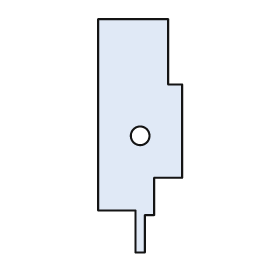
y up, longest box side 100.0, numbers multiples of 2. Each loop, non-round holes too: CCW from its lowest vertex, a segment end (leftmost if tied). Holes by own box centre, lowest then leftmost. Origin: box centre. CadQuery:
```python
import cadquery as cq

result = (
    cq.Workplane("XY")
    .moveTo(-2.0, -50.0)
    .lineTo(2.0, -50.0)
    .lineTo(2.0, -34.0)
    .lineTo(6.0, -34.0)
    .lineTo(6.0, -18.0)
    .lineTo(18.0, -18.0)
    .lineTo(18.0, 22.0)
    .lineTo(12.0, 22.0)
    .lineTo(12.0, 50.0)
    .lineTo(-18.0, 50.0)
    .lineTo(-18.0, -32.0)
    .lineTo(-2.0, -32.0)
    .close()
    .moveTo(0.0, 0.0)
    .circle(4.0)
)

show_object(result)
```